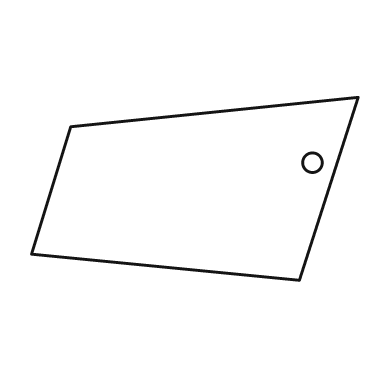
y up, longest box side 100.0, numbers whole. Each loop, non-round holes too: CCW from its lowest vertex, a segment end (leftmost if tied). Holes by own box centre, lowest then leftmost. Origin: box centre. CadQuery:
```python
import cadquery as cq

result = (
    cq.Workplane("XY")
    .moveTo(32.0, -28.0)
    .lineTo(50.0, 28.0)
    .lineTo(-38.0, 19.0)
    .lineTo(-50.0, -20.0)
    .close()
    .moveTo(36.0, 8.0)
    .circle(3.0)
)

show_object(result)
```